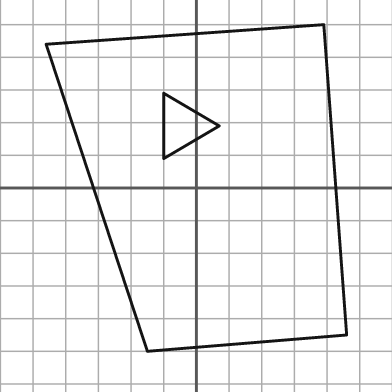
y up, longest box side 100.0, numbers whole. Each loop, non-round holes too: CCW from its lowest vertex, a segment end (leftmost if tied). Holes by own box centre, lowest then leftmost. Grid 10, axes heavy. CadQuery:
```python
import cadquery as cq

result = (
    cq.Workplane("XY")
    .moveTo(-15.0, -50.0)
    .lineTo(46.0, -45.0)
    .lineTo(39.0, 50.0)
    .lineTo(-46.0, 44.0)
    .close()
    .moveTo(-10.0, 9.0)
    .lineTo(7.0, 19.0)
    .lineTo(-10.0, 29.0)
    .close()
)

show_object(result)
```